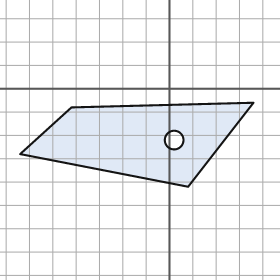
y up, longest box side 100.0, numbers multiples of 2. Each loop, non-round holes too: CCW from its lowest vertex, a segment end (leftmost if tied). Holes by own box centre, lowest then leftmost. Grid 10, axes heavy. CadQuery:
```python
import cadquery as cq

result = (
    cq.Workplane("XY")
    .moveTo(8.0, -42.0)
    .lineTo(36.0, -6.0)
    .lineTo(-42.0, -8.0)
    .lineTo(-64.0, -28.0)
    .close()
    .moveTo(2.0, -22.0)
    .circle(4.0)
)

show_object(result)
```